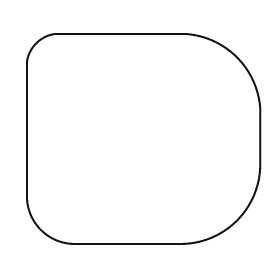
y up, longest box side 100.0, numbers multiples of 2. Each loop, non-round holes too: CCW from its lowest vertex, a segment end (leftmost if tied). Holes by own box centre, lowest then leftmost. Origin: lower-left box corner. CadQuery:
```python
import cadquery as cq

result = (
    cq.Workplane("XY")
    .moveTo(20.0, 0.0)
    .lineTo(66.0, 0.0)
    .threePointArc((90.0, 10.0), (100.0, 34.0))
    .lineTo(100.0, 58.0)
    .threePointArc((90.0, 80.0), (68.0, 90.0))
    .lineTo(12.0, 90.0)
    .threePointArc((4.0, 86.0), (0.0, 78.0))
    .lineTo(0.0, 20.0)
    .threePointArc((6.0, 6.0), (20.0, 0.0))
    .close()
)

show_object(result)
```